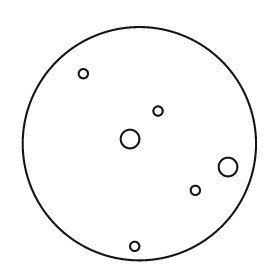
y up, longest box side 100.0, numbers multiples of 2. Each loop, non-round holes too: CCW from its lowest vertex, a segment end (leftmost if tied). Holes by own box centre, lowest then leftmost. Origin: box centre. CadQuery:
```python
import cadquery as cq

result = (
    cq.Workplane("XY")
    .moveTo(0.0, 0.0)
    .circle(50.0)
    .moveTo(-2.0, -44.0)
    .circle(2.0)
    .moveTo(24.0, -20.0)
    .circle(2.0)
    .moveTo(38.0, -10.0)
    .circle(4.0)
    .moveTo(-4.0, 2.0)
    .circle(4.0)
    .moveTo(8.0, 14.0)
    .circle(2.0)
    .moveTo(-24.0, 30.0)
    .circle(2.0)
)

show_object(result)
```